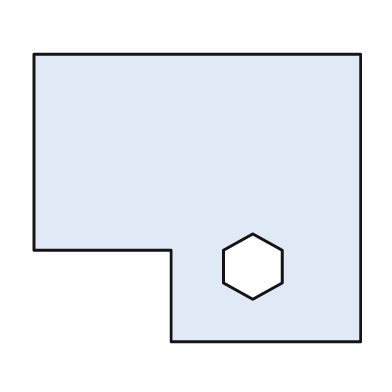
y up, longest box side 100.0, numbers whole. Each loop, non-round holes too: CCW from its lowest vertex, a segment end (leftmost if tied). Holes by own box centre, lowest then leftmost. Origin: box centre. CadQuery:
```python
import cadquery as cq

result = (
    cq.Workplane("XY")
    .moveTo(-8.0, -44.0)
    .lineTo(50.0, -44.0)
    .lineTo(50.0, 44.0)
    .lineTo(-50.0, 44.0)
    .lineTo(-50.0, -16.0)
    .lineTo(-8.0, -16.0)
    .close()
    .moveTo(17.0, -31.0)
    .lineTo(26.0, -26.0)
    .lineTo(26.0, -16.0)
    .lineTo(17.0, -11.0)
    .lineTo(8.0, -16.0)
    .lineTo(8.0, -26.0)
    .close()
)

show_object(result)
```